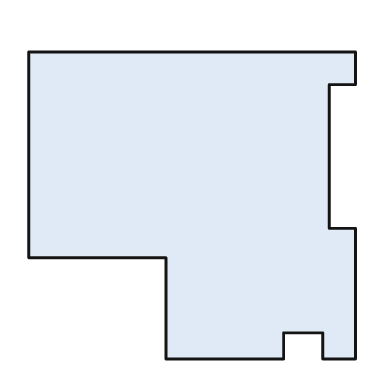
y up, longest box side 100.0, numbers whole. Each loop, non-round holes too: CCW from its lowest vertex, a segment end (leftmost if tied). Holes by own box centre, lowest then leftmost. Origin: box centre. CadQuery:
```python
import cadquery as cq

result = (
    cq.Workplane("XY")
    .moveTo(-8.0, -47.0)
    .lineTo(28.0, -47.0)
    .lineTo(28.0, -39.0)
    .lineTo(40.0, -39.0)
    .lineTo(40.0, -47.0)
    .lineTo(50.0, -47.0)
    .lineTo(50.0, -7.0)
    .lineTo(42.0, -7.0)
    .lineTo(42.0, 37.0)
    .lineTo(50.0, 37.0)
    .lineTo(50.0, 47.0)
    .lineTo(-50.0, 47.0)
    .lineTo(-50.0, -16.0)
    .lineTo(-8.0, -16.0)
    .close()
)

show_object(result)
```